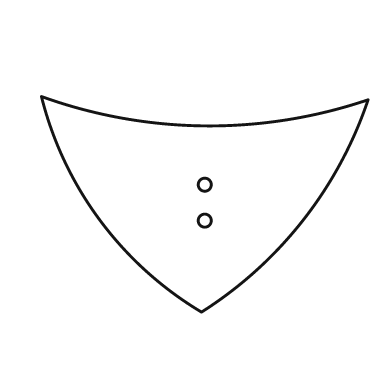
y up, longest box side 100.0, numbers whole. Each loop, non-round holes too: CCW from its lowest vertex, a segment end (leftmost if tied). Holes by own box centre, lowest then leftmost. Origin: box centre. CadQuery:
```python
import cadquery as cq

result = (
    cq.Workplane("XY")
    .moveTo(-1.0, -33.0)
    .threePointArc((30.0, -5.0), (50.0, 32.0))
    .threePointArc((0.0, 24.0), (-50.0, 33.0))
    .threePointArc((-32.0, -5.0), (-1.0, -33.0))
    .close()
    .moveTo(0.0, -5.0)
    .circle(2.0)
    .moveTo(0.0, 6.0)
    .circle(2.0)
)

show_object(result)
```